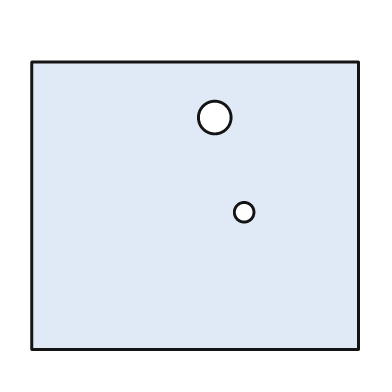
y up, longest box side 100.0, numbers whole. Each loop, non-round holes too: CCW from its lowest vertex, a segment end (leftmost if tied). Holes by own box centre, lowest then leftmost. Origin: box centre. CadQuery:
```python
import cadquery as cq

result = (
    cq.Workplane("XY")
    .moveTo(-50.0, -44.0)
    .lineTo(50.0, -44.0)
    .lineTo(50.0, 44.0)
    .lineTo(-50.0, 44.0)
    .close()
    .moveTo(15.0, -2.0)
    .circle(3.0)
    .moveTo(6.0, 27.0)
    .circle(5.0)
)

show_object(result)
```